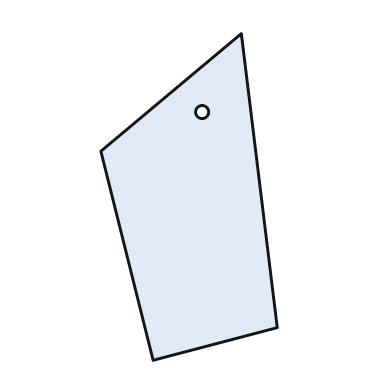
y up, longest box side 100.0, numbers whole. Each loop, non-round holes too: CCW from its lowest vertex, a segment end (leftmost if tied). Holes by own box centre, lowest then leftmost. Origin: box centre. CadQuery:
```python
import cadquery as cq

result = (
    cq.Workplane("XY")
    .moveTo(-11.0, -50.0)
    .lineTo(27.0, -40.0)
    .lineTo(16.0, 50.0)
    .lineTo(-27.0, 14.0)
    .close()
    .moveTo(4.0, 26.0)
    .circle(2.0)
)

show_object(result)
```